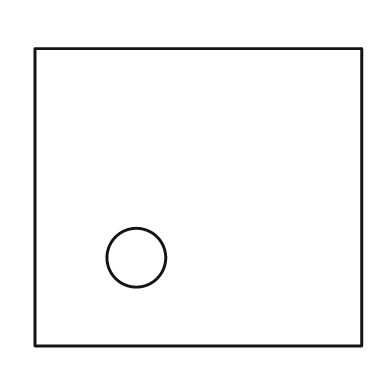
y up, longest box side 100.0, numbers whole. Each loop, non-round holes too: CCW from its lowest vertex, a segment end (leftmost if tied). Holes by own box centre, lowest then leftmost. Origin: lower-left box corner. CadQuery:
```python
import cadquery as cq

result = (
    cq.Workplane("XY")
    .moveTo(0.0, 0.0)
    .lineTo(100.0, 0.0)
    .lineTo(100.0, 91.0)
    .lineTo(0.0, 91.0)
    .close()
    .moveTo(31.0, 27.0)
    .circle(9.0)
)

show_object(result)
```